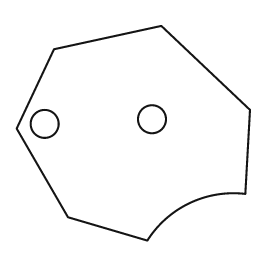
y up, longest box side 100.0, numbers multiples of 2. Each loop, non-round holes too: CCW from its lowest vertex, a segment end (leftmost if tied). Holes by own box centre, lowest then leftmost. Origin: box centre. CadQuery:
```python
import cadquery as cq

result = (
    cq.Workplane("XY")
    .moveTo(6.0, -46.0)
    .threePointArc((24.0, -30.0), (48.0, -26.0))
    .lineTo(50.0, 10.0)
    .lineTo(12.0, 46.0)
    .lineTo(-34.0, 36.0)
    .lineTo(-50.0, 2.0)
    .lineTo(-28.0, -36.0)
    .close()
    .moveTo(-38.0, 4.0)
    .circle(6.0)
    .moveTo(8.0, 6.0)
    .circle(6.0)
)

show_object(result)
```